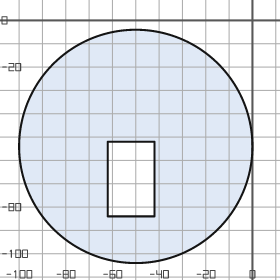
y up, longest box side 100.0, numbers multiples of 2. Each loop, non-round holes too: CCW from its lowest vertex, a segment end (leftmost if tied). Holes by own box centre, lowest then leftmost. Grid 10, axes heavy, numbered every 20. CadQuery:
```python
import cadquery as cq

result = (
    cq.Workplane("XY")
    .moveTo(-50.0, -54.0)
    .circle(50.0)
    .moveTo(-62.0, -84.0)
    .lineTo(-42.0, -84.0)
    .lineTo(-42.0, -52.0)
    .lineTo(-62.0, -52.0)
    .close()
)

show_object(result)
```